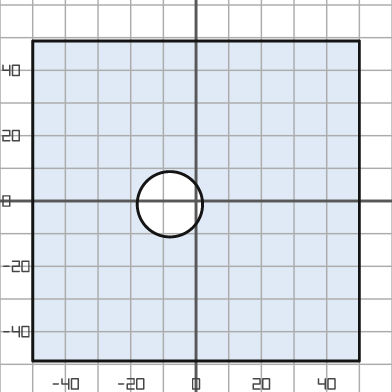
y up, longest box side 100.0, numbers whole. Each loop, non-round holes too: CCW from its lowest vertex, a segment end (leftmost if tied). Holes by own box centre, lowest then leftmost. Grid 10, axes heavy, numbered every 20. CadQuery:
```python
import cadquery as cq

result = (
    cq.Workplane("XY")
    .moveTo(-50.0, -49.0)
    .lineTo(50.0, -49.0)
    .lineTo(50.0, 49.0)
    .lineTo(-50.0, 49.0)
    .close()
    .moveTo(-8.0, -1.0)
    .circle(10.0)
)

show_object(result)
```